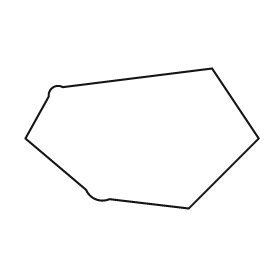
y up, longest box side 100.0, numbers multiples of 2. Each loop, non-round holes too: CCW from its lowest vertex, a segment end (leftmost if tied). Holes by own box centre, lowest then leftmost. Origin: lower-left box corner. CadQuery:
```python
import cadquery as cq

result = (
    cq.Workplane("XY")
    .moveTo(70.0, 0.0)
    .lineTo(100.0, 30.0)
    .lineTo(80.0, 60.0)
    .lineTo(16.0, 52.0)
    .threePointArc((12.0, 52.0), (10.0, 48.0))
    .lineTo(0.0, 30.0)
    .lineTo(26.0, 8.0)
    .threePointArc((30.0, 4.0), (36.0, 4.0))
    .close()
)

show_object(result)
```